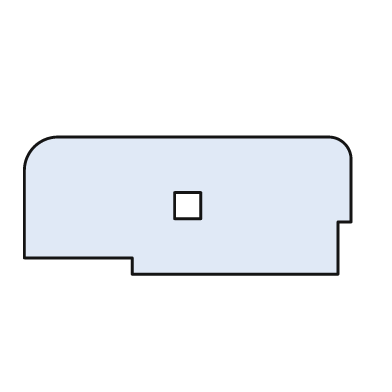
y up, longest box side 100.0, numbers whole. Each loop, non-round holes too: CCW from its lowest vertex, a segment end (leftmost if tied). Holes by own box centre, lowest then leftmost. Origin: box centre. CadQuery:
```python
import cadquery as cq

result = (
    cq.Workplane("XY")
    .moveTo(-17.0, -21.0)
    .lineTo(46.0, -21.0)
    .lineTo(46.0, -5.0)
    .lineTo(50.0, -5.0)
    .lineTo(50.0, 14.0)
    .threePointArc((48.0, 19.0), (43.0, 21.0))
    .lineTo(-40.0, 21.0)
    .threePointArc((-47.0, 18.0), (-50.0, 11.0))
    .lineTo(-50.0, -16.0)
    .lineTo(-17.0, -16.0)
    .close()
    .moveTo(-4.0, -4.0)
    .lineTo(4.0, -4.0)
    .lineTo(4.0, 4.0)
    .lineTo(-4.0, 4.0)
    .close()
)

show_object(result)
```